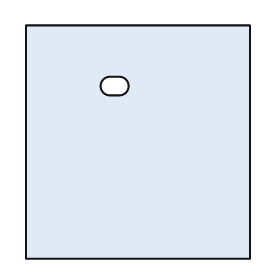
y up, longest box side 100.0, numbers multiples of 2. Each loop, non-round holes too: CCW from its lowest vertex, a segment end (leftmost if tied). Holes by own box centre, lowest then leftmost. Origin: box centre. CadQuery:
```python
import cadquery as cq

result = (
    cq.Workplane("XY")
    .moveTo(-48.0, -50.0)
    .lineTo(48.0, -50.0)
    .lineTo(48.0, 50.0)
    .lineTo(-48.0, 50.0)
    .close()
    .moveTo(-12.0, 20.0)
    .lineTo(-8.0, 20.0)
    .threePointArc((-4.0, 24.0), (-8.0, 28.0))
    .lineTo(-12.0, 28.0)
    .threePointArc((-16.0, 24.0), (-12.0, 20.0))
    .close()
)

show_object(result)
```